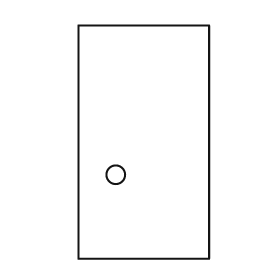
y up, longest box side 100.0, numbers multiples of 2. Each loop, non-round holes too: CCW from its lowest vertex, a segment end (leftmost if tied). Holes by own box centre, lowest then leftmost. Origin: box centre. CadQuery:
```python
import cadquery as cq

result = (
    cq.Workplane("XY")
    .moveTo(-28.0, -50.0)
    .lineTo(28.0, -50.0)
    .lineTo(28.0, 50.0)
    .lineTo(-28.0, 50.0)
    .close()
    .moveTo(-12.0, -14.0)
    .circle(4.0)
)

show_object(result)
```